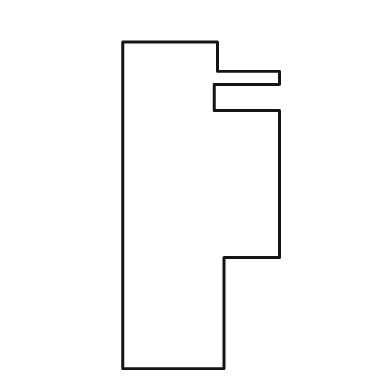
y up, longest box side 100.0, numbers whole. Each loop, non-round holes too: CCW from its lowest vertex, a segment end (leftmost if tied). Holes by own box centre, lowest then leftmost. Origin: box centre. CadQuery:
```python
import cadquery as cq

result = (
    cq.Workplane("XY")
    .moveTo(-24.0, -50.0)
    .lineTo(7.0, -50.0)
    .lineTo(7.0, -16.0)
    .lineTo(24.0, -16.0)
    .lineTo(24.0, 29.0)
    .lineTo(4.0, 29.0)
    .lineTo(4.0, 37.0)
    .lineTo(24.0, 37.0)
    .lineTo(24.0, 41.0)
    .lineTo(5.0, 41.0)
    .lineTo(5.0, 50.0)
    .lineTo(-24.0, 50.0)
    .close()
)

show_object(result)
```